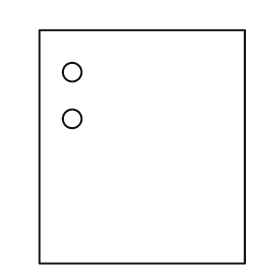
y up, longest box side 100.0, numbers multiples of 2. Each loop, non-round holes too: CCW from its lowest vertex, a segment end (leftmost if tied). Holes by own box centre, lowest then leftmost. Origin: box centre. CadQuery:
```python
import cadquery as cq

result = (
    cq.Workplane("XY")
    .moveTo(-44.0, -50.0)
    .lineTo(44.0, -50.0)
    .lineTo(44.0, 50.0)
    .lineTo(-44.0, 50.0)
    .close()
    .moveTo(-30.0, 12.0)
    .circle(4.0)
    .moveTo(-30.0, 32.0)
    .circle(4.0)
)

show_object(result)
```